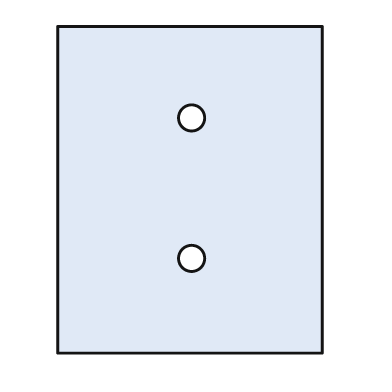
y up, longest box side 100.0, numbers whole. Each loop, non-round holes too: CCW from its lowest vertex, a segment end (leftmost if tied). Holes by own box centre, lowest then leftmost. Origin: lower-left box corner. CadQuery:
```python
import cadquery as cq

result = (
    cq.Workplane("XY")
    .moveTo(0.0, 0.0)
    .lineTo(81.0, 0.0)
    .lineTo(81.0, 100.0)
    .lineTo(0.0, 100.0)
    .close()
    .moveTo(41.0, 29.0)
    .circle(4.0)
    .moveTo(41.0, 72.0)
    .circle(4.0)
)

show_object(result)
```